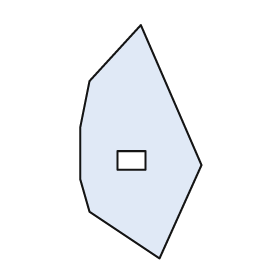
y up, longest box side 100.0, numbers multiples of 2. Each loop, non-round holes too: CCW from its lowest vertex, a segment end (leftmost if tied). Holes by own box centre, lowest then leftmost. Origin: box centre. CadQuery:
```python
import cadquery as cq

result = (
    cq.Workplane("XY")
    .moveTo(8.0, -50.0)
    .lineTo(26.0, -10.0)
    .lineTo(0.0, 50.0)
    .lineTo(-22.0, 26.0)
    .lineTo(-26.0, 6.0)
    .lineTo(-26.0, -16.0)
    .lineTo(-22.0, -30.0)
    .close()
    .moveTo(-10.0, -12.0)
    .lineTo(2.0, -12.0)
    .lineTo(2.0, -4.0)
    .lineTo(-10.0, -4.0)
    .close()
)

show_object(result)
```